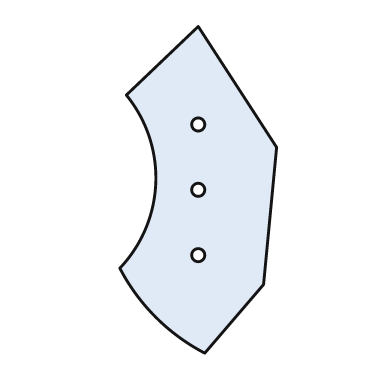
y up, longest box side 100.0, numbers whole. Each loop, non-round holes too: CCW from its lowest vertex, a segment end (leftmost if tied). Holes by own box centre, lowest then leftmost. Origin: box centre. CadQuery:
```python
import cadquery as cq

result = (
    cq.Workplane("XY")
    .moveTo(2.0, -50.0)
    .lineTo(20.0, -29.0)
    .lineTo(24.0, 13.0)
    .lineTo(0.0, 50.0)
    .lineTo(-22.0, 29.0)
    .threePointArc((-13.0, 2.0), (-24.0, -24.0))
    .threePointArc((-13.0, -39.0), (2.0, -50.0))
    .close()
    .moveTo(0.0, -20.0)
    .circle(2.0)
    .moveTo(0.0, 0.0)
    .circle(2.0)
    .moveTo(0.0, 20.0)
    .circle(2.0)
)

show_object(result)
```